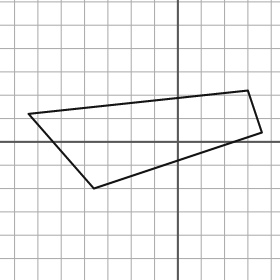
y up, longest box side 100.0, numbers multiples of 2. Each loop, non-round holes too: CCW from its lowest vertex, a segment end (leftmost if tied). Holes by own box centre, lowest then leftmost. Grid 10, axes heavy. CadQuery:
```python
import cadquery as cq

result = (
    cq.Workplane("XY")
    .moveTo(-36.0, -20.0)
    .lineTo(36.0, 4.0)
    .lineTo(30.0, 22.0)
    .lineTo(-64.0, 12.0)
    .close()
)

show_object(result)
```